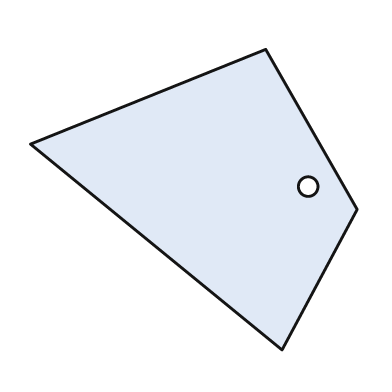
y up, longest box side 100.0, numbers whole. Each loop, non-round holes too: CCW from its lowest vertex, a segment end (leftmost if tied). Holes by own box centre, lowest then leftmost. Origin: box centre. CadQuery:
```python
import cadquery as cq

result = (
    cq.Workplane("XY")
    .moveTo(27.0, -46.0)
    .lineTo(50.0, -3.0)
    .lineTo(22.0, 46.0)
    .lineTo(-50.0, 17.0)
    .close()
    .moveTo(35.0, 4.0)
    .circle(3.0)
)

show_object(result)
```